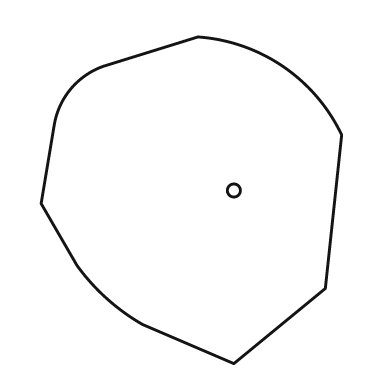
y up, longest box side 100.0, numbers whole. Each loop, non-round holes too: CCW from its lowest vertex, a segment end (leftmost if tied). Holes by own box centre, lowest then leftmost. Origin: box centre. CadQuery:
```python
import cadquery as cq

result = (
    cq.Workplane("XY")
    .moveTo(13.0, -50.0)
    .lineTo(41.0, -27.0)
    .lineTo(46.0, 20.0)
    .threePointArc((28.0, 41.0), (2.0, 50.0))
    .lineTo(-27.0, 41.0)
    .threePointArc((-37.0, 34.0), (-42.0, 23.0))
    .lineTo(-46.0, -1.0)
    .lineTo(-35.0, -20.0)
    .threePointArc((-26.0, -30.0), (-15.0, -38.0))
    .close()
    .moveTo(13.0, 3.0)
    .circle(2.0)
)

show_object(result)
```